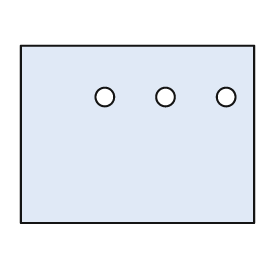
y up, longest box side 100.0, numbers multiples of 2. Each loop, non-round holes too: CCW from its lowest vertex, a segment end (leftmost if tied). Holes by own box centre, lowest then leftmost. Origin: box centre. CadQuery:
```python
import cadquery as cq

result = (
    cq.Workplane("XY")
    .moveTo(-50.0, -38.0)
    .lineTo(50.0, -38.0)
    .lineTo(50.0, 38.0)
    .lineTo(-50.0, 38.0)
    .close()
    .moveTo(-14.0, 16.0)
    .circle(4.0)
    .moveTo(12.0, 16.0)
    .circle(4.0)
    .moveTo(38.0, 16.0)
    .circle(4.0)
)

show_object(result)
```